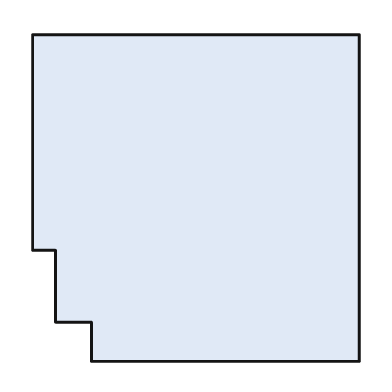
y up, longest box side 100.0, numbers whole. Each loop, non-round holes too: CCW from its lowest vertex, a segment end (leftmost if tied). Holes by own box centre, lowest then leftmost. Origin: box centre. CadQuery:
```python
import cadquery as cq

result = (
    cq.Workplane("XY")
    .moveTo(-32.0, -50.0)
    .lineTo(50.0, -50.0)
    .lineTo(50.0, 50.0)
    .lineTo(-50.0, 50.0)
    .lineTo(-50.0, -16.0)
    .lineTo(-43.0, -16.0)
    .lineTo(-43.0, -38.0)
    .lineTo(-32.0, -38.0)
    .close()
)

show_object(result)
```